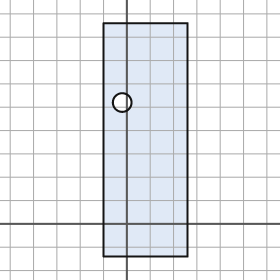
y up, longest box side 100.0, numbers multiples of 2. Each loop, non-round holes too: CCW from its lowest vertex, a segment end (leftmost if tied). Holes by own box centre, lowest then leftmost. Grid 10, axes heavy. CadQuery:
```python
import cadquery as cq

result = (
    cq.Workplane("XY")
    .moveTo(-10.0, -14.0)
    .lineTo(26.0, -14.0)
    .lineTo(26.0, 86.0)
    .lineTo(-10.0, 86.0)
    .close()
    .moveTo(-2.0, 52.0)
    .circle(4.0)
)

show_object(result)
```